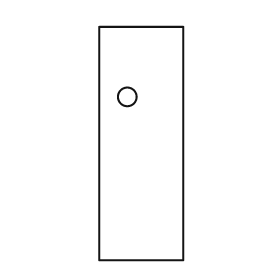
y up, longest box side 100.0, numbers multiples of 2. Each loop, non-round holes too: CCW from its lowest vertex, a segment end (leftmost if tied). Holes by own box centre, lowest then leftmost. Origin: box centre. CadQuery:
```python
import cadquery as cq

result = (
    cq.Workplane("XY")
    .moveTo(-18.0, -50.0)
    .lineTo(18.0, -50.0)
    .lineTo(18.0, 50.0)
    .lineTo(-18.0, 50.0)
    .close()
    .moveTo(-6.0, 20.0)
    .circle(4.0)
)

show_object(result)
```